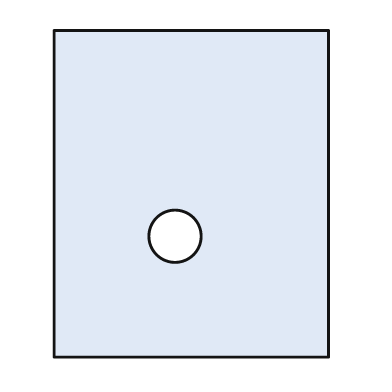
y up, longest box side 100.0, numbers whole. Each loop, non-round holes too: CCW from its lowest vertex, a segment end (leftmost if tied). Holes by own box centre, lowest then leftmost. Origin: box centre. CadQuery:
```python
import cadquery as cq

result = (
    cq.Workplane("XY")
    .moveTo(-42.0, -50.0)
    .lineTo(42.0, -50.0)
    .lineTo(42.0, 50.0)
    .lineTo(-42.0, 50.0)
    .close()
    .moveTo(-5.0, -13.0)
    .circle(8.0)
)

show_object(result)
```